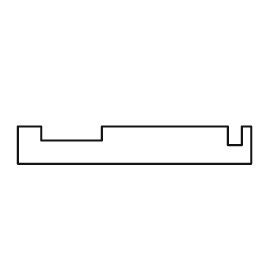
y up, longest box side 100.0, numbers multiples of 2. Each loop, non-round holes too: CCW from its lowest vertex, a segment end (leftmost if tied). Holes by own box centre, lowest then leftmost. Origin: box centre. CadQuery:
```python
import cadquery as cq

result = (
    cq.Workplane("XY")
    .moveTo(-50.0, -8.0)
    .lineTo(50.0, -8.0)
    .lineTo(50.0, 8.0)
    .lineTo(46.0, 8.0)
    .lineTo(46.0, 0.0)
    .lineTo(40.0, 0.0)
    .lineTo(40.0, 8.0)
    .lineTo(-14.0, 8.0)
    .lineTo(-14.0, 2.0)
    .lineTo(-40.0, 2.0)
    .lineTo(-40.0, 8.0)
    .lineTo(-50.0, 8.0)
    .close()
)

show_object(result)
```